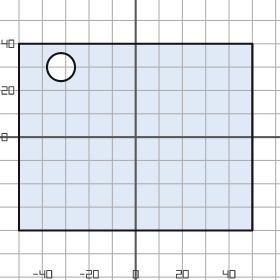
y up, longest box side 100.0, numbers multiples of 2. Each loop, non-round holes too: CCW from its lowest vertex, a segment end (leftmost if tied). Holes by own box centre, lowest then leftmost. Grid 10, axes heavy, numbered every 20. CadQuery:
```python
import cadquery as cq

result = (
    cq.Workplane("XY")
    .moveTo(-50.0, -40.0)
    .lineTo(50.0, -40.0)
    .lineTo(50.0, 40.0)
    .lineTo(-50.0, 40.0)
    .close()
    .moveTo(-32.0, 30.0)
    .circle(6.0)
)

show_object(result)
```